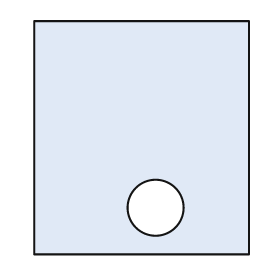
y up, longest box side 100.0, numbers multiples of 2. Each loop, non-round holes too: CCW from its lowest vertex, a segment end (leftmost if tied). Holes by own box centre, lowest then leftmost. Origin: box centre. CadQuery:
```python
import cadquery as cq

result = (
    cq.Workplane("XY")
    .moveTo(-46.0, -50.0)
    .lineTo(46.0, -50.0)
    .lineTo(46.0, 50.0)
    .lineTo(-46.0, 50.0)
    .close()
    .moveTo(6.0, -30.0)
    .circle(12.0)
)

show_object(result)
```